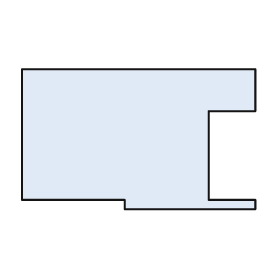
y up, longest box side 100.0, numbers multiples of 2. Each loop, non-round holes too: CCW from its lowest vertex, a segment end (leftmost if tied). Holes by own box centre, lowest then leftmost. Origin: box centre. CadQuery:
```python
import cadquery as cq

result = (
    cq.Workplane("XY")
    .moveTo(-6.0, -30.0)
    .lineTo(50.0, -30.0)
    .lineTo(50.0, -26.0)
    .lineTo(30.0, -26.0)
    .lineTo(30.0, 12.0)
    .lineTo(50.0, 12.0)
    .lineTo(50.0, 30.0)
    .lineTo(-50.0, 30.0)
    .lineTo(-50.0, -26.0)
    .lineTo(-6.0, -26.0)
    .close()
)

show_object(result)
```